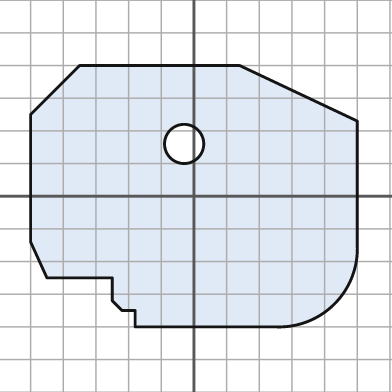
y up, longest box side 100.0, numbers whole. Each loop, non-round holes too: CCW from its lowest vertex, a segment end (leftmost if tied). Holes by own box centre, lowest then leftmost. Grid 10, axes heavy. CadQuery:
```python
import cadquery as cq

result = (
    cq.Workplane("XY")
    .moveTo(-18.0, -40.0)
    .lineTo(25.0, -40.0)
    .threePointArc((43.0, -33.0), (50.0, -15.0))
    .lineTo(50.0, 23.0)
    .lineTo(14.0, 40.0)
    .lineTo(-35.0, 40.0)
    .lineTo(-50.0, 25.0)
    .lineTo(-50.0, -14.0)
    .lineTo(-45.0, -25.0)
    .lineTo(-25.0, -25.0)
    .lineTo(-25.0, -32.0)
    .lineTo(-22.0, -35.0)
    .lineTo(-18.0, -35.0)
    .close()
    .moveTo(-3.0, 16.0)
    .circle(6.0)
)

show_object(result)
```